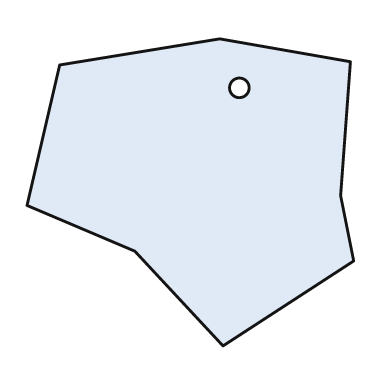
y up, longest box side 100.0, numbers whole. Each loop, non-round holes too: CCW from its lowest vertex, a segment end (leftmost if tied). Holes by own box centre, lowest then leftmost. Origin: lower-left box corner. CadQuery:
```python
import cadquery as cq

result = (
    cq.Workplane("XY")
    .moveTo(60.0, 0.0)
    .lineTo(100.0, 26.0)
    .lineTo(96.0, 46.0)
    .lineTo(99.0, 87.0)
    .lineTo(59.0, 94.0)
    .lineTo(10.0, 86.0)
    .lineTo(0.0, 43.0)
    .lineTo(33.0, 29.0)
    .close()
    .moveTo(65.0, 79.0)
    .circle(3.0)
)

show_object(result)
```